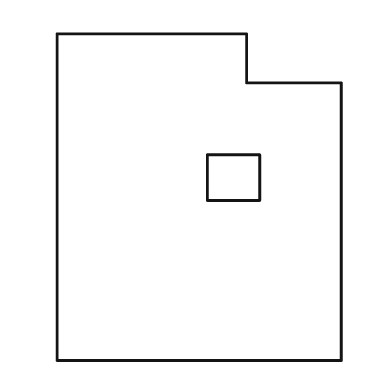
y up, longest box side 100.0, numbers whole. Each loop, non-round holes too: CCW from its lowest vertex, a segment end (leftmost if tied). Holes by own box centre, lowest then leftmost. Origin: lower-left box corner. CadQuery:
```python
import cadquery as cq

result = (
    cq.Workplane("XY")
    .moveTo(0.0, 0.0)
    .lineTo(87.0, 0.0)
    .lineTo(87.0, 85.0)
    .lineTo(58.0, 85.0)
    .lineTo(58.0, 100.0)
    .lineTo(0.0, 100.0)
    .close()
    .moveTo(46.0, 49.0)
    .lineTo(62.0, 49.0)
    .lineTo(62.0, 63.0)
    .lineTo(46.0, 63.0)
    .close()
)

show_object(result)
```